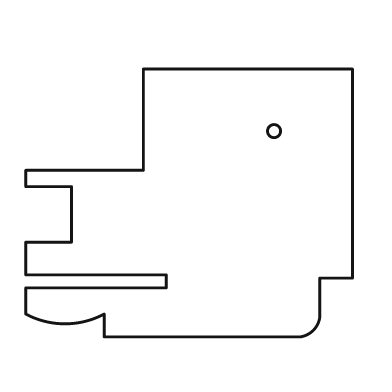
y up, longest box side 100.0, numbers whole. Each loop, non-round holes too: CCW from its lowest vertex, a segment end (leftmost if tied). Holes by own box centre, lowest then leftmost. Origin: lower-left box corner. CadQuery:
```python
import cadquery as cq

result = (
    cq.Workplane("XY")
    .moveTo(24.0, 0.0)
    .lineTo(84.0, 0.0)
    .threePointArc((88.0, 2.0), (90.0, 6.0))
    .lineTo(90.0, 18.0)
    .lineTo(100.0, 18.0)
    .lineTo(100.0, 82.0)
    .lineTo(36.0, 82.0)
    .lineTo(36.0, 51.0)
    .lineTo(0.0, 51.0)
    .lineTo(0.0, 46.0)
    .lineTo(14.0, 46.0)
    .lineTo(14.0, 29.0)
    .lineTo(0.0, 29.0)
    .lineTo(0.0, 19.0)
    .lineTo(43.0, 19.0)
    .lineTo(43.0, 15.0)
    .lineTo(0.0, 15.0)
    .lineTo(0.0, 7.0)
    .threePointArc((12.0, 4.0), (24.0, 7.0))
    .close()
    .moveTo(76.0, 63.0)
    .circle(2.0)
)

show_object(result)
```